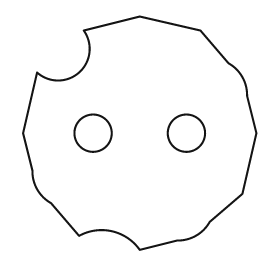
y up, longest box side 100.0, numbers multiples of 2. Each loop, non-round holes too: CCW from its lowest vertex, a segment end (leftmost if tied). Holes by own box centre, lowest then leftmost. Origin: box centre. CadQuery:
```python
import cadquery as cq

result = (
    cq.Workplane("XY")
    .moveTo(0.0, -50.0)
    .lineTo(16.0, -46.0)
    .threePointArc((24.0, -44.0), (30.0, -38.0))
    .lineTo(44.0, -26.0)
    .lineTo(50.0, 0.0)
    .lineTo(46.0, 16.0)
    .threePointArc((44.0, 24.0), (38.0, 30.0))
    .lineTo(26.0, 44.0)
    .lineTo(0.0, 50.0)
    .lineTo(-24.0, 44.0)
    .threePointArc((-26.0, 26.0), (-44.0, 26.0))
    .lineTo(-50.0, 0.0)
    .lineTo(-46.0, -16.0)
    .threePointArc((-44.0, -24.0), (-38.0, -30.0))
    .lineTo(-26.0, -44.0)
    .threePointArc((-12.0, -42.0), (0.0, -50.0))
    .close()
    .moveTo(-20.0, 0.0)
    .circle(8.0)
    .moveTo(20.0, 0.0)
    .circle(8.0)
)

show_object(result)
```